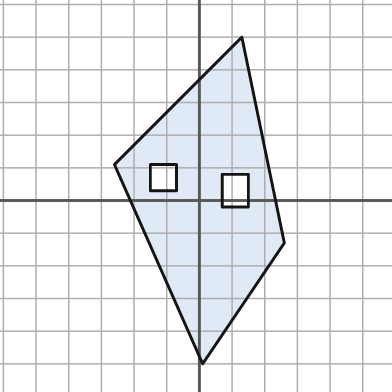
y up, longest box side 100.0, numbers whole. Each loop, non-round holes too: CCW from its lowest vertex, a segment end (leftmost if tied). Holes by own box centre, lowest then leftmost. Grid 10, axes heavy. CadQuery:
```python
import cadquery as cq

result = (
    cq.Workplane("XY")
    .moveTo(1.0, -50.0)
    .lineTo(26.0, -13.0)
    .lineTo(13.0, 50.0)
    .lineTo(-26.0, 11.0)
    .close()
    .moveTo(7.0, -2.0)
    .lineTo(15.0, -2.0)
    .lineTo(15.0, 8.0)
    .lineTo(7.0, 8.0)
    .close()
    .moveTo(-15.0, 3.0)
    .lineTo(-7.0, 3.0)
    .lineTo(-7.0, 11.0)
    .lineTo(-15.0, 11.0)
    .close()
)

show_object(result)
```